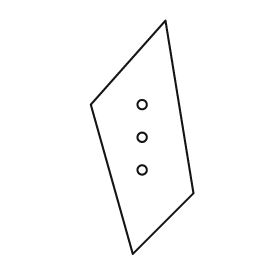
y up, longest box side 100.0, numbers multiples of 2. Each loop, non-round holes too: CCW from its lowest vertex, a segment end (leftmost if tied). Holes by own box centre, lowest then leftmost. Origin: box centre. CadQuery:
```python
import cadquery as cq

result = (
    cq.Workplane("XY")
    .moveTo(-4.0, -50.0)
    .lineTo(22.0, -24.0)
    .lineTo(10.0, 50.0)
    .lineTo(-22.0, 14.0)
    .close()
    .moveTo(0.0, -14.0)
    .circle(2.0)
    .moveTo(0.0, 0.0)
    .circle(2.0)
    .moveTo(0.0, 14.0)
    .circle(2.0)
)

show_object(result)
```